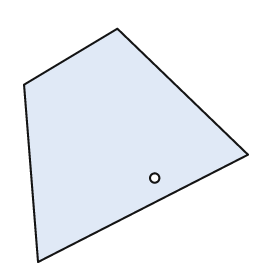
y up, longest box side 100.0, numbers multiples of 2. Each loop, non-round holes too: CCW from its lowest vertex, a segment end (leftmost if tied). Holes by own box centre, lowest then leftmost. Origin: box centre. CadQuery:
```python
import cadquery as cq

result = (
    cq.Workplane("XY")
    .moveTo(-42.0, -50.0)
    .lineTo(48.0, -4.0)
    .lineTo(-8.0, 50.0)
    .lineTo(-48.0, 26.0)
    .close()
    .moveTo(8.0, -14.0)
    .circle(2.0)
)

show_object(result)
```